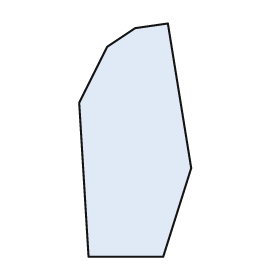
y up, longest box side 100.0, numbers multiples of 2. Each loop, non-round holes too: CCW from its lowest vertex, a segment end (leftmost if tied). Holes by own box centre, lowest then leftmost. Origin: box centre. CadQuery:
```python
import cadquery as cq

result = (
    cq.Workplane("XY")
    .moveTo(-20.0, -50.0)
    .lineTo(12.0, -50.0)
    .lineTo(24.0, -12.0)
    .lineTo(14.0, 50.0)
    .lineTo(0.0, 48.0)
    .lineTo(-12.0, 40.0)
    .lineTo(-24.0, 16.0)
    .close()
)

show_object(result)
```